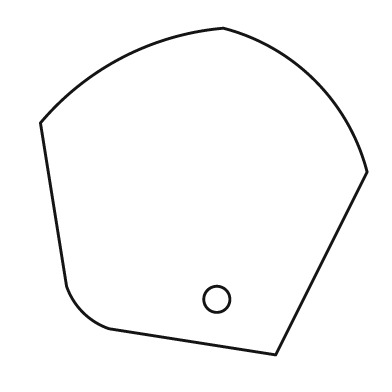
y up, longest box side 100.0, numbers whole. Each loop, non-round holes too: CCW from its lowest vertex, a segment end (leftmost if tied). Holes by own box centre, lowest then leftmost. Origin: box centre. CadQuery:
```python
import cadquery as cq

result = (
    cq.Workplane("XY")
    .moveTo(22.0, -50.0)
    .lineTo(50.0, 6.0)
    .threePointArc((34.0, 34.0), (6.0, 50.0))
    .threePointArc((-25.0, 41.0), (-50.0, 21.0))
    .lineTo(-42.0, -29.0)
    .threePointArc((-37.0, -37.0), (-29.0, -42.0))
    .close()
    .moveTo(4.0, -33.0)
    .circle(4.0)
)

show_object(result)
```